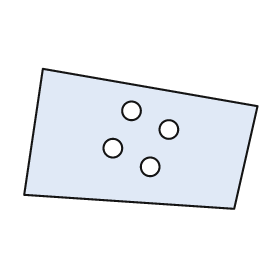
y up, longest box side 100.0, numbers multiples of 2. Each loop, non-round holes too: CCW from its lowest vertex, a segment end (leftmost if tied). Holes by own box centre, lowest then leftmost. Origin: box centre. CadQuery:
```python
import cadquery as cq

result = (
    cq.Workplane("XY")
    .moveTo(40.0, -30.0)
    .lineTo(50.0, 14.0)
    .lineTo(-42.0, 30.0)
    .lineTo(-50.0, -24.0)
    .close()
    .moveTo(4.0, -12.0)
    .circle(4.0)
    .moveTo(-12.0, -4.0)
    .circle(4.0)
    .moveTo(12.0, 4.0)
    .circle(4.0)
    .moveTo(-4.0, 12.0)
    .circle(4.0)
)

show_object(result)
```